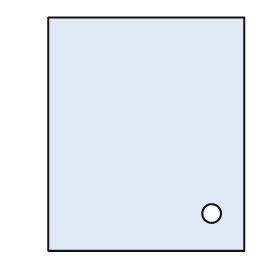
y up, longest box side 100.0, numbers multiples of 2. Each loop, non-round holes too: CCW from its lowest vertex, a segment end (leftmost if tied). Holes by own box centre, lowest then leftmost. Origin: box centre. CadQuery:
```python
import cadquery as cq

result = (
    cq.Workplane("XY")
    .moveTo(-42.0, -50.0)
    .lineTo(42.0, -50.0)
    .lineTo(42.0, 50.0)
    .lineTo(-42.0, 50.0)
    .close()
    .moveTo(28.0, -34.0)
    .circle(4.0)
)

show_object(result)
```